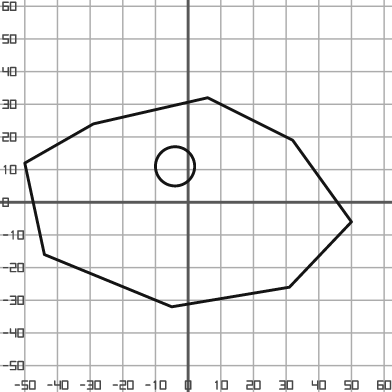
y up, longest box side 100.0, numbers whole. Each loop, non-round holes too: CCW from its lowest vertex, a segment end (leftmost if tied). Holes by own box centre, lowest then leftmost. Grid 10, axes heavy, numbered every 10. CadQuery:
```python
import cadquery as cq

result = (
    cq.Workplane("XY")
    .moveTo(-5.0, -32.0)
    .lineTo(31.0, -26.0)
    .lineTo(50.0, -6.0)
    .lineTo(32.0, 19.0)
    .lineTo(6.0, 32.0)
    .lineTo(-29.0, 24.0)
    .lineTo(-50.0, 12.0)
    .lineTo(-44.0, -16.0)
    .close()
    .moveTo(-4.0, 11.0)
    .circle(6.0)
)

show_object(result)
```